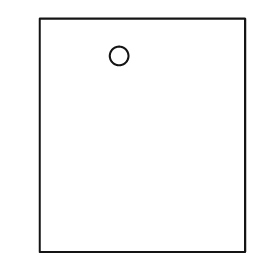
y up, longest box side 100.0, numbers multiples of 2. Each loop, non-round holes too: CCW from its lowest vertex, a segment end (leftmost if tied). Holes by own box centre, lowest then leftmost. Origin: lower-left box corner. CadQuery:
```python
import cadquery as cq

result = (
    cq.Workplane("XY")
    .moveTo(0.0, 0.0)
    .lineTo(88.0, 0.0)
    .lineTo(88.0, 100.0)
    .lineTo(0.0, 100.0)
    .close()
    .moveTo(34.0, 84.0)
    .circle(4.0)
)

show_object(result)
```